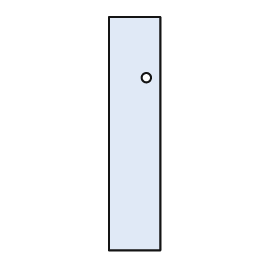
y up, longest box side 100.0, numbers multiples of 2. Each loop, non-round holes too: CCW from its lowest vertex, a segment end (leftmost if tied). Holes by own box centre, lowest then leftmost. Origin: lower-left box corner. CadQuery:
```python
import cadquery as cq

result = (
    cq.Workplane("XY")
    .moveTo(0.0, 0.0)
    .lineTo(22.0, 0.0)
    .lineTo(22.0, 100.0)
    .lineTo(0.0, 100.0)
    .close()
    .moveTo(16.0, 74.0)
    .circle(2.0)
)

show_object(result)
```